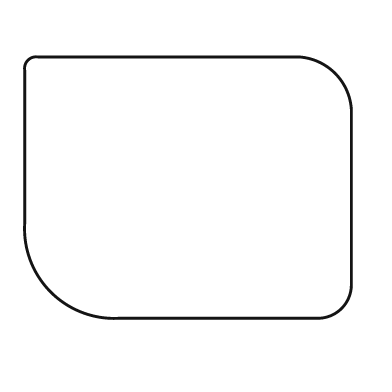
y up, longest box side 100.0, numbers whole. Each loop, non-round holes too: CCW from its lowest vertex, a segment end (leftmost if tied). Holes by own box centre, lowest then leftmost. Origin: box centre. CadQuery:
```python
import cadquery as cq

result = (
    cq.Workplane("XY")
    .moveTo(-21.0, -40.0)
    .lineTo(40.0, -40.0)
    .threePointArc((47.0, -37.0), (50.0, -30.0))
    .lineTo(50.0, 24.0)
    .threePointArc((45.0, 35.0), (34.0, 40.0))
    .lineTo(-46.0, 40.0)
    .threePointArc((-49.0, 39.0), (-50.0, 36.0))
    .lineTo(-50.0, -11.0)
    .threePointArc((-42.0, -32.0), (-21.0, -40.0))
    .close()
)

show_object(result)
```